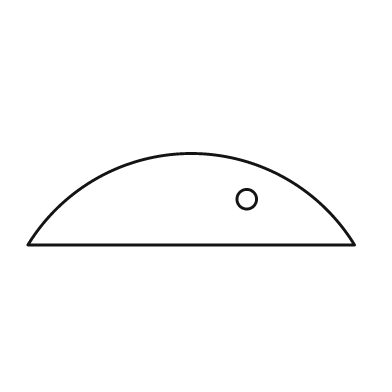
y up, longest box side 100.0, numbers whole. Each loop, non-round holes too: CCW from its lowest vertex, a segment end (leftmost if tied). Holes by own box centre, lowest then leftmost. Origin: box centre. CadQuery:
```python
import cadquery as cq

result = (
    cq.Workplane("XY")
    .moveTo(-50.0, -14.0)
    .lineTo(50.0, -14.0)
    .threePointArc((0.0, 14.0), (-50.0, -14.0))
    .close()
    .moveTo(17.0, 0.0)
    .circle(3.0)
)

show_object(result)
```